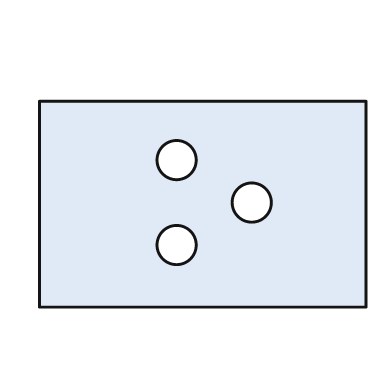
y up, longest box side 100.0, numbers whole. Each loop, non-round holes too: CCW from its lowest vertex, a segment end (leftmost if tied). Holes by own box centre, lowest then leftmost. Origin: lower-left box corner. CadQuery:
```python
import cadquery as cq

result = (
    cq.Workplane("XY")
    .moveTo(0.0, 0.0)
    .lineTo(100.0, 0.0)
    .lineTo(100.0, 63.0)
    .lineTo(0.0, 63.0)
    .close()
    .moveTo(42.0, 19.0)
    .circle(6.0)
    .moveTo(65.0, 32.0)
    .circle(6.0)
    .moveTo(42.0, 45.0)
    .circle(6.0)
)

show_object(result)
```